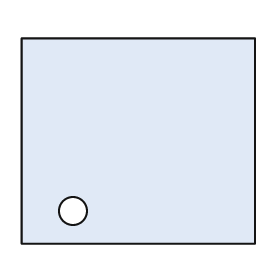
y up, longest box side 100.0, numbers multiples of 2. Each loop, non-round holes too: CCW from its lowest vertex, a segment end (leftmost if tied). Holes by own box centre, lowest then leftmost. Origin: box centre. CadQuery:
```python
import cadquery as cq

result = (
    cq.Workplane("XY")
    .moveTo(-50.0, -44.0)
    .lineTo(50.0, -44.0)
    .lineTo(50.0, 44.0)
    .lineTo(-50.0, 44.0)
    .close()
    .moveTo(-28.0, -30.0)
    .circle(6.0)
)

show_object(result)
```